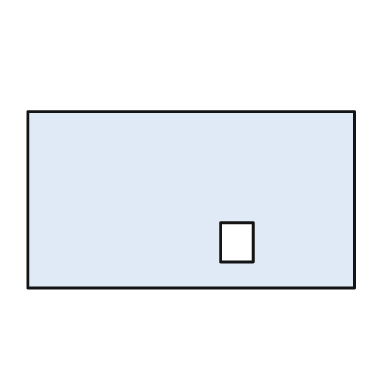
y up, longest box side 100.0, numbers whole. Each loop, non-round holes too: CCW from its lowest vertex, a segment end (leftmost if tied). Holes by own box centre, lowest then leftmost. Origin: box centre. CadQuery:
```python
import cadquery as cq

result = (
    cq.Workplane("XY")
    .moveTo(-50.0, -27.0)
    .lineTo(50.0, -27.0)
    .lineTo(50.0, 27.0)
    .lineTo(-50.0, 27.0)
    .close()
    .moveTo(9.0, -19.0)
    .lineTo(19.0, -19.0)
    .lineTo(19.0, -7.0)
    .lineTo(9.0, -7.0)
    .close()
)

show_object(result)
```